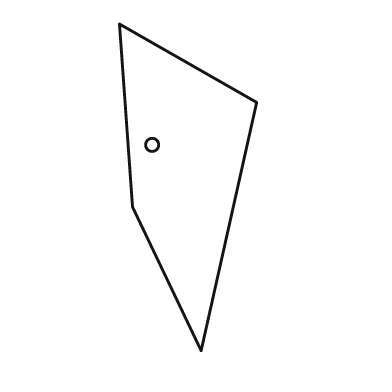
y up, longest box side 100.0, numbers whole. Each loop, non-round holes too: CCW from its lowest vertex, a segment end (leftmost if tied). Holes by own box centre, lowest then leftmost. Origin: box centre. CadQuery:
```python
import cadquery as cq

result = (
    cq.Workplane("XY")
    .moveTo(4.0, -50.0)
    .lineTo(21.0, 26.0)
    .lineTo(-21.0, 50.0)
    .lineTo(-17.0, -6.0)
    .close()
    .moveTo(-11.0, 13.0)
    .circle(2.0)
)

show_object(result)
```